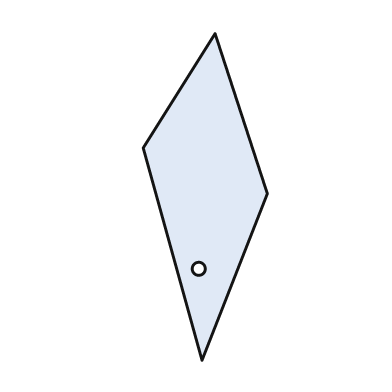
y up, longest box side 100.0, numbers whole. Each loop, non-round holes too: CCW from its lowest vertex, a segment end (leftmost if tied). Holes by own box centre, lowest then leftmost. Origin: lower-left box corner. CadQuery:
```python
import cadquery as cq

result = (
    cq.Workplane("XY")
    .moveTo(18.0, 0.0)
    .lineTo(38.0, 51.0)
    .lineTo(22.0, 100.0)
    .lineTo(0.0, 65.0)
    .close()
    .moveTo(17.0, 28.0)
    .circle(2.0)
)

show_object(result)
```